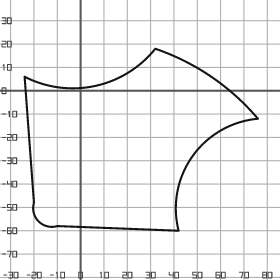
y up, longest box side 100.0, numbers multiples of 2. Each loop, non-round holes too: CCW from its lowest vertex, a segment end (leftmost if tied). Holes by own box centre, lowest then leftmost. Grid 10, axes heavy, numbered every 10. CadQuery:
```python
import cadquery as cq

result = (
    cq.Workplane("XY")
    .moveTo(42.0, -60.0)
    .threePointArc((48.0, -28.0), (76.0, -12.0))
    .threePointArc((56.0, 6.0), (32.0, 18.0))
    .threePointArc((6.0, 2.0), (-24.0, 6.0))
    .lineTo(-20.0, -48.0)
    .threePointArc((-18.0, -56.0), (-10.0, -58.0))
    .close()
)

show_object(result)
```